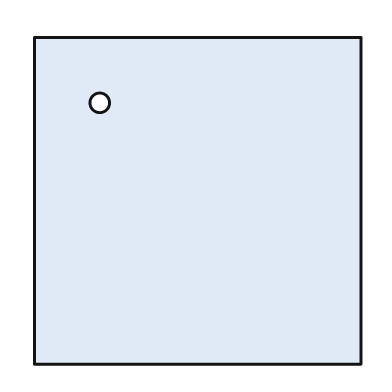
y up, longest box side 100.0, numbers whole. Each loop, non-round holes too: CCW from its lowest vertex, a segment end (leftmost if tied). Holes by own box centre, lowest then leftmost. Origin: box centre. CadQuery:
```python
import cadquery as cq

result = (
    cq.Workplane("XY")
    .moveTo(-50.0, -50.0)
    .lineTo(50.0, -50.0)
    .lineTo(50.0, 50.0)
    .lineTo(-50.0, 50.0)
    .close()
    .moveTo(-30.0, 30.0)
    .circle(3.0)
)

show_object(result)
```